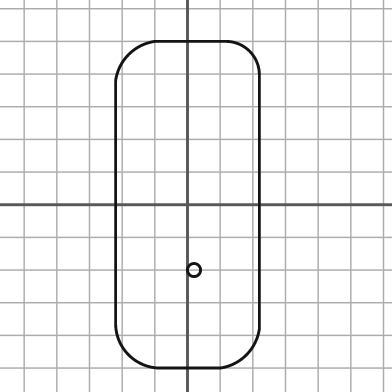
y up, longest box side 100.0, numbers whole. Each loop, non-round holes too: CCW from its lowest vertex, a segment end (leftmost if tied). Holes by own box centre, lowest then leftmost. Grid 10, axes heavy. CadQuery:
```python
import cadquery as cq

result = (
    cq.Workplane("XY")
    .moveTo(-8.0, -50.0)
    .lineTo(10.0, -50.0)
    .threePointArc((18.0, -46.0), (22.0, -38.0))
    .lineTo(22.0, 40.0)
    .threePointArc((19.0, 47.0), (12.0, 50.0))
    .lineTo(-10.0, 50.0)
    .threePointArc((-18.0, 46.0), (-22.0, 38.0))
    .lineTo(-22.0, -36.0)
    .threePointArc((-18.0, -46.0), (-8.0, -50.0))
    .close()
    .moveTo(2.0, -20.0)
    .circle(2.0)
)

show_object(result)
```